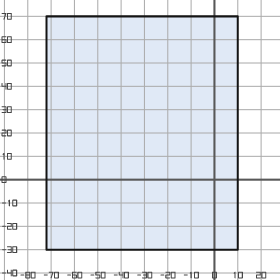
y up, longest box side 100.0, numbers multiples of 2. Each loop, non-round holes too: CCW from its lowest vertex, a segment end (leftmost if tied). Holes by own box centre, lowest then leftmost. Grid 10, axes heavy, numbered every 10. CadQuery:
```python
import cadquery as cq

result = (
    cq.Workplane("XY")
    .moveTo(-72.0, -30.0)
    .lineTo(10.0, -30.0)
    .lineTo(10.0, 70.0)
    .lineTo(-72.0, 70.0)
    .close()
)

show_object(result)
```